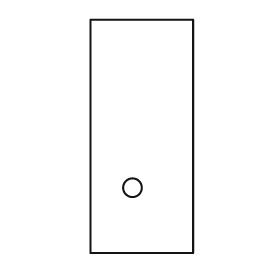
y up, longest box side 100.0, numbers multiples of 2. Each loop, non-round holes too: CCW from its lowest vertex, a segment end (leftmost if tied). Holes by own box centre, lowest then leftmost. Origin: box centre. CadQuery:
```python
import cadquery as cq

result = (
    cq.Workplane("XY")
    .moveTo(-22.0, -50.0)
    .lineTo(22.0, -50.0)
    .lineTo(22.0, 50.0)
    .lineTo(-22.0, 50.0)
    .close()
    .moveTo(-4.0, -22.0)
    .circle(4.0)
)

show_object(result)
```